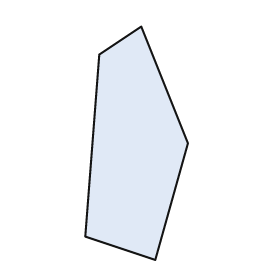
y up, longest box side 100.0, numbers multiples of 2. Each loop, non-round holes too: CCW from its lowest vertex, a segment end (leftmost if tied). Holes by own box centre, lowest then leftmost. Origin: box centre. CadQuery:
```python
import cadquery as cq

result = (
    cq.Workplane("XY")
    .moveTo(8.0, -50.0)
    .lineTo(22.0, 0.0)
    .lineTo(2.0, 50.0)
    .lineTo(-16.0, 38.0)
    .lineTo(-22.0, -40.0)
    .close()
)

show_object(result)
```